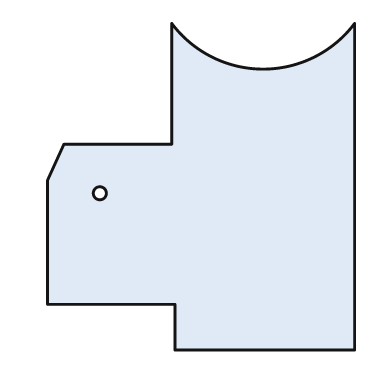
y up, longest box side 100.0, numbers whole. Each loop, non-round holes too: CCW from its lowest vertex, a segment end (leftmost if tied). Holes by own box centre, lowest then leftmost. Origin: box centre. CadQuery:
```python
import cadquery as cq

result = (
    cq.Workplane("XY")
    .moveTo(-8.0, -50.0)
    .lineTo(47.0, -50.0)
    .lineTo(47.0, 50.0)
    .threePointArc((19.0, 36.0), (-9.0, 50.0))
    .lineTo(-9.0, 13.0)
    .lineTo(-42.0, 13.0)
    .lineTo(-47.0, 2.0)
    .lineTo(-47.0, -36.0)
    .lineTo(-8.0, -36.0)
    .close()
    .moveTo(-31.0, -2.0)
    .circle(2.0)
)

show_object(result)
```